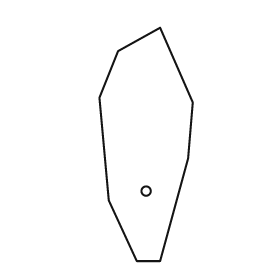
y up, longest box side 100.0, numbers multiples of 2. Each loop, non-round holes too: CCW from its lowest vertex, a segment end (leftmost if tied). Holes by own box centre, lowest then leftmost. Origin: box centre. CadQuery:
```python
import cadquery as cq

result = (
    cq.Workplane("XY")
    .moveTo(-4.0, -50.0)
    .lineTo(6.0, -50.0)
    .lineTo(18.0, -6.0)
    .lineTo(20.0, 18.0)
    .lineTo(6.0, 50.0)
    .lineTo(-12.0, 40.0)
    .lineTo(-20.0, 20.0)
    .lineTo(-16.0, -24.0)
    .close()
    .moveTo(0.0, -20.0)
    .circle(2.0)
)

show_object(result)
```